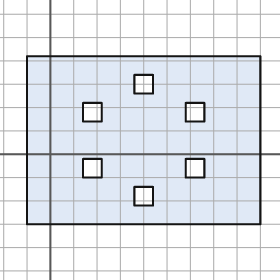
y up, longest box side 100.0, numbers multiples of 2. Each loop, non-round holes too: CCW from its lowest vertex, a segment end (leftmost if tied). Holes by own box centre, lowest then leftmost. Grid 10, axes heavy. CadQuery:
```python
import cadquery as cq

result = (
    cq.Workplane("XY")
    .moveTo(-10.0, -30.0)
    .lineTo(90.0, -30.0)
    .lineTo(90.0, 42.0)
    .lineTo(-10.0, 42.0)
    .close()
    .moveTo(36.0, -22.0)
    .lineTo(44.0, -22.0)
    .lineTo(44.0, -14.0)
    .lineTo(36.0, -14.0)
    .close()
    .moveTo(14.0, -10.0)
    .lineTo(22.0, -10.0)
    .lineTo(22.0, -2.0)
    .lineTo(14.0, -2.0)
    .close()
    .moveTo(58.0, -10.0)
    .lineTo(66.0, -10.0)
    .lineTo(66.0, -2.0)
    .lineTo(58.0, -2.0)
    .close()
    .moveTo(14.0, 14.0)
    .lineTo(22.0, 14.0)
    .lineTo(22.0, 22.0)
    .lineTo(14.0, 22.0)
    .close()
    .moveTo(58.0, 14.0)
    .lineTo(66.0, 14.0)
    .lineTo(66.0, 22.0)
    .lineTo(58.0, 22.0)
    .close()
    .moveTo(36.0, 26.0)
    .lineTo(44.0, 26.0)
    .lineTo(44.0, 34.0)
    .lineTo(36.0, 34.0)
    .close()
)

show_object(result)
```